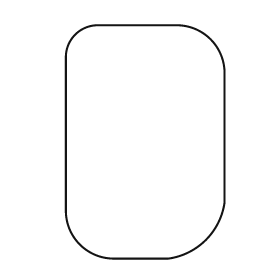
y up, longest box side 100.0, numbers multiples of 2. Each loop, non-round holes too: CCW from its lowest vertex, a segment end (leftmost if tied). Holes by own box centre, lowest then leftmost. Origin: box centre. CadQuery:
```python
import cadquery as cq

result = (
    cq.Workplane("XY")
    .moveTo(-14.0, -50.0)
    .lineTo(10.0, -50.0)
    .threePointArc((26.0, -42.0), (34.0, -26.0))
    .lineTo(34.0, 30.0)
    .threePointArc((28.0, 44.0), (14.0, 50.0))
    .lineTo(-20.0, 50.0)
    .threePointArc((-30.0, 46.0), (-34.0, 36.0))
    .lineTo(-34.0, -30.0)
    .threePointArc((-28.0, -44.0), (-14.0, -50.0))
    .close()
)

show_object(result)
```